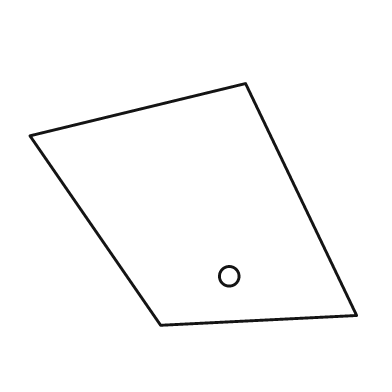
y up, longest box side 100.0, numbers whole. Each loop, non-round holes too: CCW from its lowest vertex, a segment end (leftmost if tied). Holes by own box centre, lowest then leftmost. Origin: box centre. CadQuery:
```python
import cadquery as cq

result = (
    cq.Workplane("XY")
    .moveTo(-10.0, -37.0)
    .lineTo(50.0, -34.0)
    .lineTo(16.0, 37.0)
    .lineTo(-50.0, 21.0)
    .close()
    .moveTo(11.0, -22.0)
    .circle(3.0)
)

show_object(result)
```